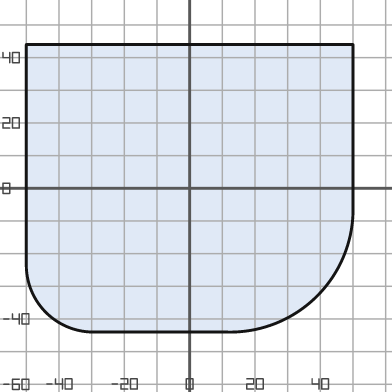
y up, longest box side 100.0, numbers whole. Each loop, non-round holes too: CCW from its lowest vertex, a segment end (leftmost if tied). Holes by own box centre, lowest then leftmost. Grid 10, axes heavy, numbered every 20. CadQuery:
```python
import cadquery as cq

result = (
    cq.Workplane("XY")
    .moveTo(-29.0, -44.0)
    .lineTo(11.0, -44.0)
    .threePointArc((39.0, -33.0), (50.0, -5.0))
    .lineTo(50.0, 44.0)
    .lineTo(-50.0, 44.0)
    .lineTo(-50.0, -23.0)
    .threePointArc((-44.0, -38.0), (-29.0, -44.0))
    .close()
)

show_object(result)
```